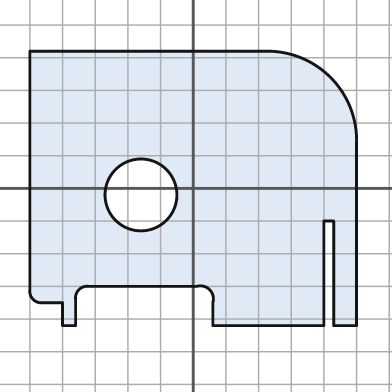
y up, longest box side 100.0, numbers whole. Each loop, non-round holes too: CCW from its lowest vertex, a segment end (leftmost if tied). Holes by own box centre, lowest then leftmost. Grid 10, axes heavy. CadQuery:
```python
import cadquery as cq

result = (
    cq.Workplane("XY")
    .moveTo(-40.0, -42.0)
    .lineTo(-36.0, -42.0)
    .lineTo(-36.0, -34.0)
    .threePointArc((-35.0, -31.0), (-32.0, -30.0))
    .lineTo(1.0, -30.0)
    .threePointArc((5.0, -31.0), (6.0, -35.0))
    .lineTo(6.0, -42.0)
    .lineTo(40.0, -42.0)
    .lineTo(40.0, -10.0)
    .lineTo(43.0, -10.0)
    .lineTo(43.0, -42.0)
    .lineTo(50.0, -42.0)
    .lineTo(50.0, 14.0)
    .threePointArc((42.0, 34.0), (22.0, 42.0))
    .lineTo(-50.0, 42.0)
    .lineTo(-50.0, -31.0)
    .threePointArc((-49.0, -34.0), (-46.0, -35.0))
    .lineTo(-40.0, -35.0)
    .close()
    .moveTo(-16.0, -2.0)
    .circle(11.0)
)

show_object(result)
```